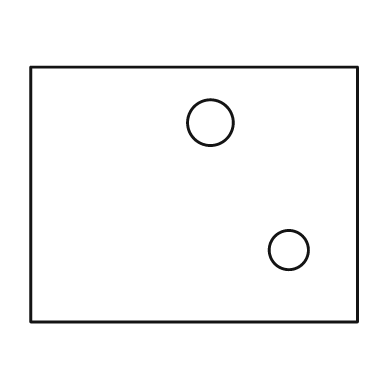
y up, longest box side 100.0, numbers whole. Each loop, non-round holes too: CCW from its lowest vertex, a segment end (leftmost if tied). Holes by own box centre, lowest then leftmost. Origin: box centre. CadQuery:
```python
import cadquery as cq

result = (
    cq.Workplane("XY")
    .moveTo(-50.0, -39.0)
    .lineTo(50.0, -39.0)
    .lineTo(50.0, 39.0)
    .lineTo(-50.0, 39.0)
    .close()
    .moveTo(29.0, -17.0)
    .circle(6.0)
    .moveTo(5.0, 22.0)
    .circle(7.0)
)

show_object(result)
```